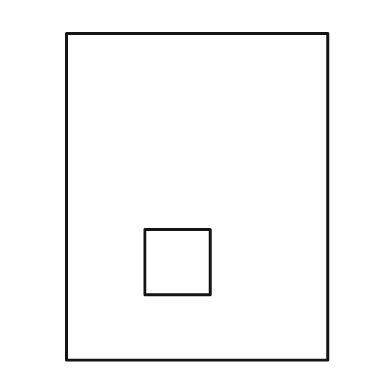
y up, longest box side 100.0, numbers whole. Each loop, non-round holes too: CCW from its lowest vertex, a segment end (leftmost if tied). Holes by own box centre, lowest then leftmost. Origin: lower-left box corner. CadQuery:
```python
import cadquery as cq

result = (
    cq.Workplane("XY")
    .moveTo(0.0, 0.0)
    .lineTo(80.0, 0.0)
    .lineTo(80.0, 100.0)
    .lineTo(0.0, 100.0)
    .close()
    .moveTo(24.0, 20.0)
    .lineTo(44.0, 20.0)
    .lineTo(44.0, 40.0)
    .lineTo(24.0, 40.0)
    .close()
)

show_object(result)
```